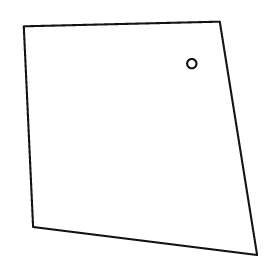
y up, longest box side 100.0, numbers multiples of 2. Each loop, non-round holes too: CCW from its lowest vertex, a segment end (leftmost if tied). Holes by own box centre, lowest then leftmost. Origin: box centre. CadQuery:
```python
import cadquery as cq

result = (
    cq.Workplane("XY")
    .moveTo(50.0, -50.0)
    .lineTo(34.0, 50.0)
    .lineTo(-50.0, 48.0)
    .lineTo(-46.0, -38.0)
    .close()
    .moveTo(22.0, 32.0)
    .circle(2.0)
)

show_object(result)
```